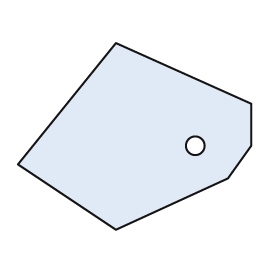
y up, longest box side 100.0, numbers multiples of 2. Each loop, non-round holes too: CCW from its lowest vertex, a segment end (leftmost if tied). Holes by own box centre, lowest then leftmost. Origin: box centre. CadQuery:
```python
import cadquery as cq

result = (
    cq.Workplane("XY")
    .moveTo(-8.0, -40.0)
    .lineTo(40.0, -18.0)
    .lineTo(50.0, -4.0)
    .lineTo(50.0, 14.0)
    .lineTo(-8.0, 40.0)
    .lineTo(-50.0, -12.0)
    .close()
    .moveTo(26.0, -4.0)
    .circle(4.0)
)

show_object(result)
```